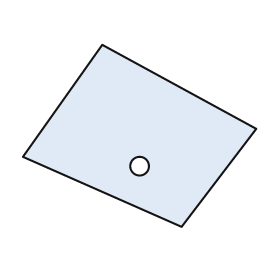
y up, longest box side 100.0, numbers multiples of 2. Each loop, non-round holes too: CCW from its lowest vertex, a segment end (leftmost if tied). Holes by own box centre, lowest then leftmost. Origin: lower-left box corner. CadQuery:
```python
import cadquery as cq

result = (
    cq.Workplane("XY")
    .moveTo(68.0, 0.0)
    .lineTo(100.0, 42.0)
    .lineTo(34.0, 78.0)
    .lineTo(0.0, 30.0)
    .close()
    .moveTo(50.0, 26.0)
    .circle(4.0)
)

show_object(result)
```